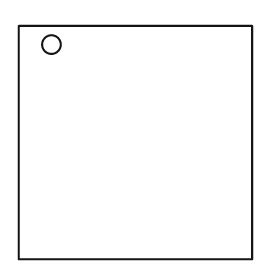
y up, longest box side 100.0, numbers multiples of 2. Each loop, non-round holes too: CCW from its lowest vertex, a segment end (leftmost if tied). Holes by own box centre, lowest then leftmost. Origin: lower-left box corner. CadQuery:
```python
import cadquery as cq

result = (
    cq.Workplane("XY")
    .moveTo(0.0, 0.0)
    .lineTo(100.0, 0.0)
    .lineTo(100.0, 100.0)
    .lineTo(0.0, 100.0)
    .close()
    .moveTo(14.0, 92.0)
    .circle(4.0)
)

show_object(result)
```